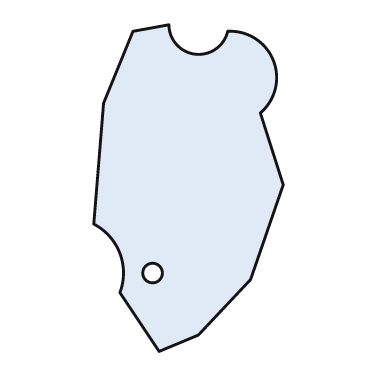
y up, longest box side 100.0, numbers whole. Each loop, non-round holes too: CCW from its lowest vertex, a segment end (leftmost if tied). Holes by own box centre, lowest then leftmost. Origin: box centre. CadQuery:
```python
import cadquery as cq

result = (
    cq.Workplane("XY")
    .moveTo(-9.0, -50.0)
    .lineTo(3.0, -45.0)
    .lineTo(19.0, -28.0)
    .lineTo(29.0, 1.0)
    .lineTo(22.0, 23.0)
    .threePointArc((26.0, 39.0), (12.0, 48.0))
    .threePointArc((2.0, 41.0), (-6.0, 50.0))
    .lineTo(-17.0, 48.0)
    .lineTo(-26.0, 26.0)
    .lineTo(-29.0, -11.0)
    .threePointArc((-21.0, -20.0), (-21.0, -32.0))
    .close()
    .moveTo(-11.0, -26.0)
    .circle(3.0)
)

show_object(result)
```